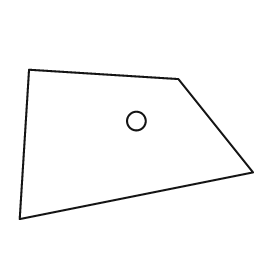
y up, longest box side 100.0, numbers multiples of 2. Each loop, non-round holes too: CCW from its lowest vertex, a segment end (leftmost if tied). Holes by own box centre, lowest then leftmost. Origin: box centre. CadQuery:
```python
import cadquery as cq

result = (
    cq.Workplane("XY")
    .moveTo(-50.0, -32.0)
    .lineTo(50.0, -12.0)
    .lineTo(18.0, 28.0)
    .lineTo(-46.0, 32.0)
    .close()
    .moveTo(0.0, 10.0)
    .circle(4.0)
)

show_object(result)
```